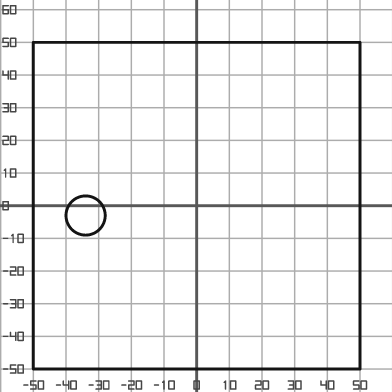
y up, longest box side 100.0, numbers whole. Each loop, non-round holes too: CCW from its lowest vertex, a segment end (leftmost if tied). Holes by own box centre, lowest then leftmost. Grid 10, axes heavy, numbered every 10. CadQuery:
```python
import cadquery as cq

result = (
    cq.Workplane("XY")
    .moveTo(-50.0, -50.0)
    .lineTo(50.0, -50.0)
    .lineTo(50.0, 50.0)
    .lineTo(-50.0, 50.0)
    .close()
    .moveTo(-34.0, -3.0)
    .circle(6.0)
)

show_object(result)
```